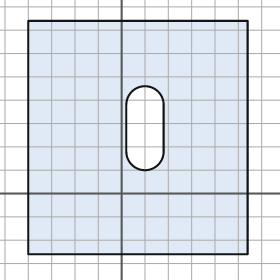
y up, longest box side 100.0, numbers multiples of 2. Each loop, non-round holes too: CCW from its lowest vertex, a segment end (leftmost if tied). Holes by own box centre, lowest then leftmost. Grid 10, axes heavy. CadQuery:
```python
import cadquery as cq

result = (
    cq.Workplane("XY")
    .moveTo(-40.0, -26.0)
    .lineTo(54.0, -26.0)
    .lineTo(54.0, 74.0)
    .lineTo(-40.0, 74.0)
    .close()
    .moveTo(2.0, 18.0)
    .threePointArc((10.0, 10.0), (18.0, 18.0))
    .lineTo(18.0, 38.0)
    .threePointArc((10.0, 46.0), (2.0, 38.0))
    .close()
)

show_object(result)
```